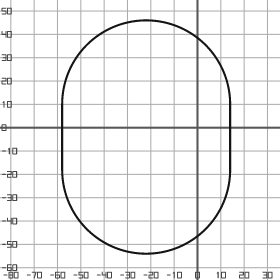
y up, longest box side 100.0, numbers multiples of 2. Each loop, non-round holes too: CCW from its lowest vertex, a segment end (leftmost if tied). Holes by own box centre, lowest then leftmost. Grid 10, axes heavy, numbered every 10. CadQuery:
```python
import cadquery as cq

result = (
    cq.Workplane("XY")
    .moveTo(-58.0, -18.0)
    .threePointArc((-22.0, -54.0), (14.0, -18.0))
    .lineTo(14.0, 10.0)
    .threePointArc((-22.0, 46.0), (-58.0, 10.0))
    .close()
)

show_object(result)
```